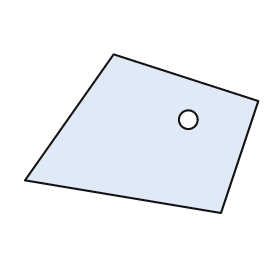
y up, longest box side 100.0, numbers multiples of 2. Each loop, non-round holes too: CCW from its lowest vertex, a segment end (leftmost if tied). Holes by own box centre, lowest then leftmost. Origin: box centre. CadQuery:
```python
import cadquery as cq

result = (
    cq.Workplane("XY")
    .moveTo(34.0, -34.0)
    .lineTo(50.0, 14.0)
    .lineTo(-12.0, 34.0)
    .lineTo(-50.0, -20.0)
    .close()
    .moveTo(20.0, 6.0)
    .circle(4.0)
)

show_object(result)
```